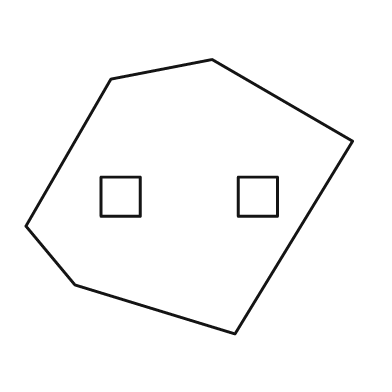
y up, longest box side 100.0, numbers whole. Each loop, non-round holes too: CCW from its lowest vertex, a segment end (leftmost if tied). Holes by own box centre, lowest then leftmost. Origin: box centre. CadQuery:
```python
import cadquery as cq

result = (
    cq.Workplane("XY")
    .moveTo(14.0, -42.0)
    .lineTo(50.0, 17.0)
    .lineTo(7.0, 42.0)
    .lineTo(-24.0, 36.0)
    .lineTo(-50.0, -9.0)
    .lineTo(-35.0, -27.0)
    .close()
    .moveTo(-27.0, -6.0)
    .lineTo(-15.0, -6.0)
    .lineTo(-15.0, 6.0)
    .lineTo(-27.0, 6.0)
    .close()
    .moveTo(15.0, -6.0)
    .lineTo(27.0, -6.0)
    .lineTo(27.0, 6.0)
    .lineTo(15.0, 6.0)
    .close()
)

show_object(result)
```